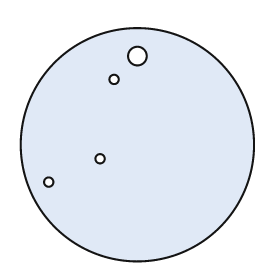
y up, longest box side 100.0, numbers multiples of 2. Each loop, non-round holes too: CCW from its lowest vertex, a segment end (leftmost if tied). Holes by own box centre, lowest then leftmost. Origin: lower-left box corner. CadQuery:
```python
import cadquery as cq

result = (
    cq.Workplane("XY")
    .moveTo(50.0, 50.0)
    .circle(50.0)
    .moveTo(12.0, 34.0)
    .circle(2.0)
    .moveTo(34.0, 44.0)
    .circle(2.0)
    .moveTo(40.0, 78.0)
    .circle(2.0)
    .moveTo(50.0, 88.0)
    .circle(4.0)
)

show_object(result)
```